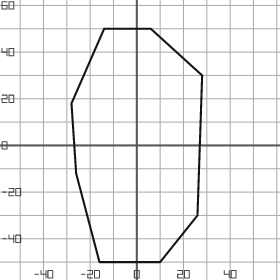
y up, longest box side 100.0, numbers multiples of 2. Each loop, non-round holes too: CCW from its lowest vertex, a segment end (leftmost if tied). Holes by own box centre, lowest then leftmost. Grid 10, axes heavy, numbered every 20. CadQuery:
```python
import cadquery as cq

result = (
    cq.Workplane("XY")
    .moveTo(-16.0, -50.0)
    .lineTo(10.0, -50.0)
    .lineTo(26.0, -30.0)
    .lineTo(28.0, 30.0)
    .lineTo(6.0, 50.0)
    .lineTo(-14.0, 50.0)
    .lineTo(-28.0, 18.0)
    .lineTo(-26.0, -12.0)
    .close()
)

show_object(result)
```